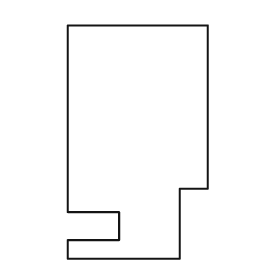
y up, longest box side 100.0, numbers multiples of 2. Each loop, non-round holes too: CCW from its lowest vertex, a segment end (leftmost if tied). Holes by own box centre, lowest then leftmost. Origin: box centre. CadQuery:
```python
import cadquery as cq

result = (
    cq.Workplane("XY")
    .moveTo(-30.0, -50.0)
    .lineTo(18.0, -50.0)
    .lineTo(18.0, -20.0)
    .lineTo(30.0, -20.0)
    .lineTo(30.0, 50.0)
    .lineTo(-30.0, 50.0)
    .lineTo(-30.0, -30.0)
    .lineTo(-8.0, -30.0)
    .lineTo(-8.0, -42.0)
    .lineTo(-30.0, -42.0)
    .close()
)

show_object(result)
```